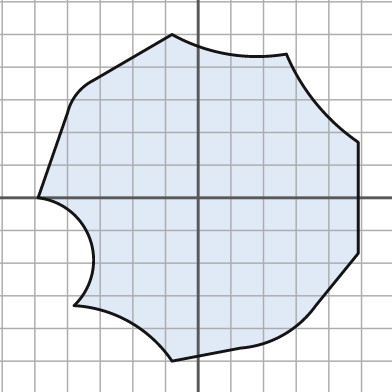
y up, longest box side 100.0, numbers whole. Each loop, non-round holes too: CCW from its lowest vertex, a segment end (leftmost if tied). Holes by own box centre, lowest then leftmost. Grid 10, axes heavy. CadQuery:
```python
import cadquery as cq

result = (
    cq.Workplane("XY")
    .moveTo(-8.0, -50.0)
    .lineTo(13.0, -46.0)
    .threePointArc((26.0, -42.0), (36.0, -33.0))
    .lineTo(49.0, -17.0)
    .lineTo(49.0, 17.0)
    .threePointArc((36.0, 29.0), (27.0, 44.0))
    .threePointArc((9.0, 44.0), (-8.0, 50.0))
    .lineTo(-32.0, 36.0)
    .threePointArc((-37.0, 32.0), (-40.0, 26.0))
    .lineTo(-49.0, 0.0)
    .threePointArc((-33.0, -13.0), (-38.0, -33.0))
    .threePointArc((-21.0, -38.0), (-8.0, -50.0))
    .close()
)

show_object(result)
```